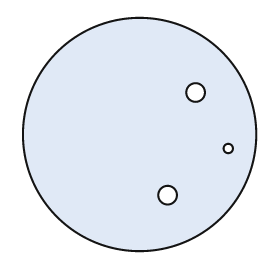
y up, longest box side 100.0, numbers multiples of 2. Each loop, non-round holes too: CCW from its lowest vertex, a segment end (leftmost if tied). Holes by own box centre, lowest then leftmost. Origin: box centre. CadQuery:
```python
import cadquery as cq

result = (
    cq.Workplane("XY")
    .moveTo(0.0, 0.0)
    .circle(50.0)
    .moveTo(12.0, -26.0)
    .circle(4.0)
    .moveTo(38.0, -6.0)
    .circle(2.0)
    .moveTo(24.0, 18.0)
    .circle(4.0)
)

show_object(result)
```